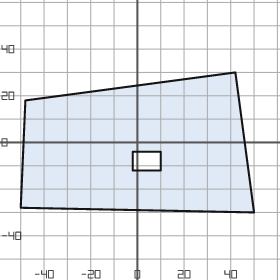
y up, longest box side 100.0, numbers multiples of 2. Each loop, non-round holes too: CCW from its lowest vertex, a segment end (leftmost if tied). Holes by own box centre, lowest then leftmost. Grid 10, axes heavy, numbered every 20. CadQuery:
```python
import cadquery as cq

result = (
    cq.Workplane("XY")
    .moveTo(50.0, -30.0)
    .lineTo(42.0, 30.0)
    .lineTo(-48.0, 18.0)
    .lineTo(-50.0, -28.0)
    .close()
    .moveTo(-2.0, -12.0)
    .lineTo(10.0, -12.0)
    .lineTo(10.0, -4.0)
    .lineTo(-2.0, -4.0)
    .close()
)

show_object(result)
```